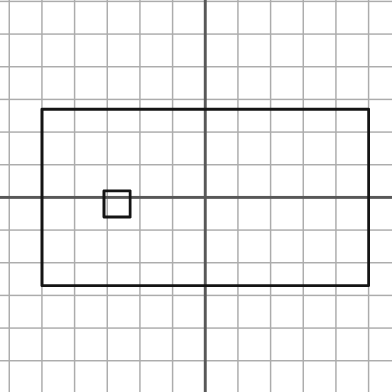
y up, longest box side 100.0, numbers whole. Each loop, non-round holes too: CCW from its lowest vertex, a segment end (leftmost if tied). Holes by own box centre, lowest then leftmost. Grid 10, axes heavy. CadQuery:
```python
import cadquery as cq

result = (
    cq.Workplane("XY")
    .moveTo(-50.0, -27.0)
    .lineTo(50.0, -27.0)
    .lineTo(50.0, 27.0)
    .lineTo(-50.0, 27.0)
    .close()
    .moveTo(-31.0, -6.0)
    .lineTo(-23.0, -6.0)
    .lineTo(-23.0, 2.0)
    .lineTo(-31.0, 2.0)
    .close()
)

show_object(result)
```